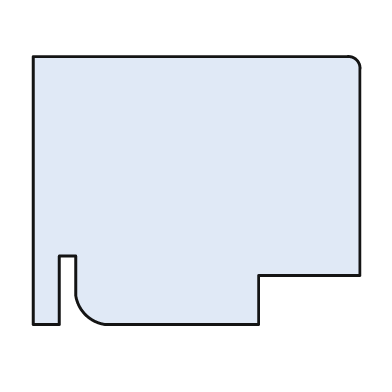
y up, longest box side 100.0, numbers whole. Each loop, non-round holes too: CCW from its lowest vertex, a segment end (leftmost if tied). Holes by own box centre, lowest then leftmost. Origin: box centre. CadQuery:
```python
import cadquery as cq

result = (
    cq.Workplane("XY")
    .moveTo(-50.0, -41.0)
    .lineTo(-42.0, -41.0)
    .lineTo(-42.0, -20.0)
    .lineTo(-37.0, -20.0)
    .lineTo(-37.0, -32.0)
    .threePointArc((-34.0, -38.0), (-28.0, -41.0))
    .lineTo(19.0, -41.0)
    .lineTo(19.0, -26.0)
    .lineTo(50.0, -26.0)
    .lineTo(50.0, 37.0)
    .threePointArc((49.0, 40.0), (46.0, 41.0))
    .lineTo(-50.0, 41.0)
    .close()
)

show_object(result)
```